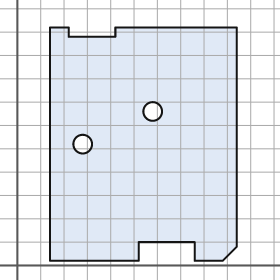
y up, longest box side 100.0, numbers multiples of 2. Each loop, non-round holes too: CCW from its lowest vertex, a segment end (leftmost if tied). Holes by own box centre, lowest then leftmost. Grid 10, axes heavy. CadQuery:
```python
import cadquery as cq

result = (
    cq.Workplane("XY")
    .moveTo(14.0, 2.0)
    .lineTo(52.0, 2.0)
    .lineTo(52.0, 10.0)
    .lineTo(76.0, 10.0)
    .lineTo(76.0, 2.0)
    .lineTo(88.0, 2.0)
    .lineTo(94.0, 8.0)
    .lineTo(94.0, 102.0)
    .lineTo(42.0, 102.0)
    .lineTo(42.0, 98.0)
    .lineTo(22.0, 98.0)
    .lineTo(22.0, 102.0)
    .lineTo(14.0, 102.0)
    .close()
    .moveTo(28.0, 52.0)
    .circle(4.0)
    .moveTo(58.0, 66.0)
    .circle(4.0)
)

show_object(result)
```